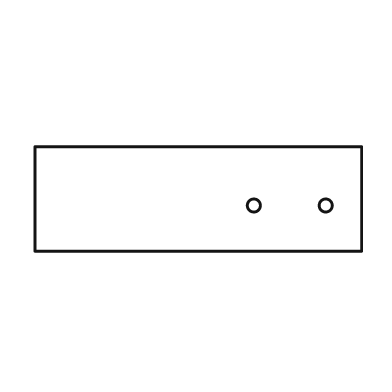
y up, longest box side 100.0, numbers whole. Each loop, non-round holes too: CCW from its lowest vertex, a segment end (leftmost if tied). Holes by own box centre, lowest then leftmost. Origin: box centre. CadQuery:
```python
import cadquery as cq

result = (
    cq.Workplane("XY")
    .moveTo(-50.0, -16.0)
    .lineTo(50.0, -16.0)
    .lineTo(50.0, 16.0)
    .lineTo(-50.0, 16.0)
    .close()
    .moveTo(17.0, -2.0)
    .circle(2.0)
    .moveTo(39.0, -2.0)
    .circle(2.0)
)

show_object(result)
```